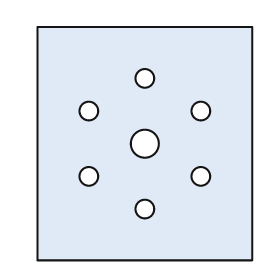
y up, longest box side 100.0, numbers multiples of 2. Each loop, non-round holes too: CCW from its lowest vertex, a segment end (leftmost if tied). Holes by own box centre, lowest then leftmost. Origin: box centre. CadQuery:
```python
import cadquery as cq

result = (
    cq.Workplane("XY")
    .moveTo(-46.0, -50.0)
    .lineTo(46.0, -50.0)
    .lineTo(46.0, 50.0)
    .lineTo(-46.0, 50.0)
    .close()
    .moveTo(0.0, -28.0)
    .circle(4.0)
    .moveTo(-24.0, -14.0)
    .circle(4.0)
    .moveTo(24.0, -14.0)
    .circle(4.0)
    .moveTo(0.0, 0.0)
    .circle(6.0)
    .moveTo(-24.0, 14.0)
    .circle(4.0)
    .moveTo(24.0, 14.0)
    .circle(4.0)
    .moveTo(0.0, 28.0)
    .circle(4.0)
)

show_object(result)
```